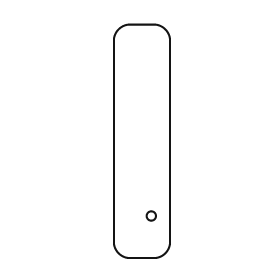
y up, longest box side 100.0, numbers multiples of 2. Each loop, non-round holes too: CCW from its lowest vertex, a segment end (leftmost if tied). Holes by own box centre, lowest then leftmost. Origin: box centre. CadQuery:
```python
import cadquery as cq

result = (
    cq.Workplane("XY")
    .moveTo(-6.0, -50.0)
    .lineTo(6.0, -50.0)
    .threePointArc((10.0, -48.0), (12.0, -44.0))
    .lineTo(12.0, 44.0)
    .threePointArc((10.0, 48.0), (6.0, 50.0))
    .lineTo(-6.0, 50.0)
    .threePointArc((-10.0, 48.0), (-12.0, 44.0))
    .lineTo(-12.0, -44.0)
    .threePointArc((-10.0, -48.0), (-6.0, -50.0))
    .close()
    .moveTo(4.0, -32.0)
    .circle(2.0)
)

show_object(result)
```